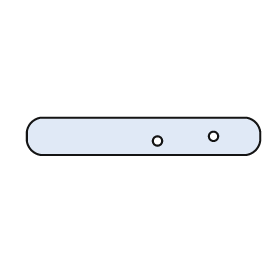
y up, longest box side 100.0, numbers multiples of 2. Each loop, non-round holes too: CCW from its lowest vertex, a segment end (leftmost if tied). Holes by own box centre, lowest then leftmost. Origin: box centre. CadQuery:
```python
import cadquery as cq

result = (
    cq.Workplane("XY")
    .moveTo(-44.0, -8.0)
    .lineTo(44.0, -8.0)
    .threePointArc((48.0, -6.0), (50.0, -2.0))
    .lineTo(50.0, 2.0)
    .threePointArc((48.0, 6.0), (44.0, 8.0))
    .lineTo(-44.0, 8.0)
    .threePointArc((-48.0, 6.0), (-50.0, 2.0))
    .lineTo(-50.0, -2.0)
    .threePointArc((-48.0, -6.0), (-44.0, -8.0))
    .close()
    .moveTo(6.0, -2.0)
    .circle(2.0)
    .moveTo(30.0, 0.0)
    .circle(2.0)
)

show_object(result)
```